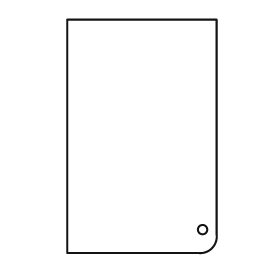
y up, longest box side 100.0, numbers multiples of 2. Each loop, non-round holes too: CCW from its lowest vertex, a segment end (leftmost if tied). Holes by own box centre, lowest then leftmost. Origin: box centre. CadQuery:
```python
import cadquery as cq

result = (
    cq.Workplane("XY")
    .moveTo(-32.0, -50.0)
    .lineTo(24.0, -50.0)
    .threePointArc((30.0, -48.0), (32.0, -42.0))
    .lineTo(32.0, 50.0)
    .lineTo(-32.0, 50.0)
    .close()
    .moveTo(26.0, -40.0)
    .circle(2.0)
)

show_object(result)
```